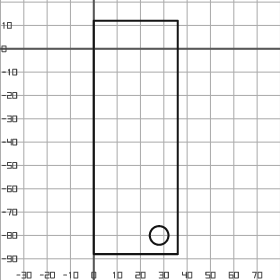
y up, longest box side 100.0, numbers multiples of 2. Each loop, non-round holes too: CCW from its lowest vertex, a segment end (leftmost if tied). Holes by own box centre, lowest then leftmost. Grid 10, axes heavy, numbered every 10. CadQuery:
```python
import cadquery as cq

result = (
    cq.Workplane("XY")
    .moveTo(0.0, -88.0)
    .lineTo(36.0, -88.0)
    .lineTo(36.0, 12.0)
    .lineTo(0.0, 12.0)
    .close()
    .moveTo(28.0, -80.0)
    .circle(4.0)
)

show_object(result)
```